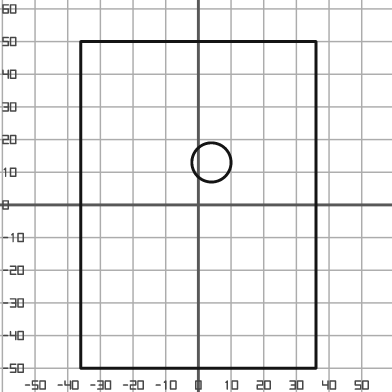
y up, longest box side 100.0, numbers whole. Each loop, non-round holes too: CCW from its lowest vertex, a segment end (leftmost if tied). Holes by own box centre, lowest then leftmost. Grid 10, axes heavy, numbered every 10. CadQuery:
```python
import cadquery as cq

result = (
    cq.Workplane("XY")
    .moveTo(-36.0, -50.0)
    .lineTo(36.0, -50.0)
    .lineTo(36.0, 50.0)
    .lineTo(-36.0, 50.0)
    .close()
    .moveTo(4.0, 13.0)
    .circle(6.0)
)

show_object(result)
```